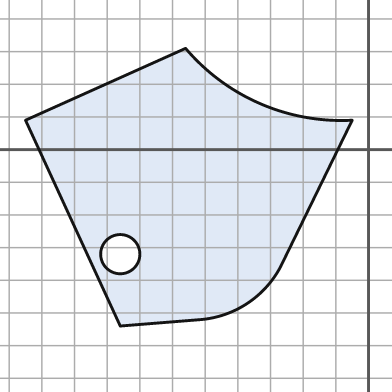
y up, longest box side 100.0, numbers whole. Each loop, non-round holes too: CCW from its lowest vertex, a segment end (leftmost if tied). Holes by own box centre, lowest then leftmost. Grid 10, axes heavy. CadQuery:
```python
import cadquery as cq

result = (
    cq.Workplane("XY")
    .moveTo(-76.0, -54.0)
    .lineTo(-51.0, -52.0)
    .threePointArc((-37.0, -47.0), (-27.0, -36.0))
    .lineTo(-5.0, 9.0)
    .threePointArc((-33.0, 14.0), (-56.0, 31.0))
    .lineTo(-105.0, 9.0)
    .close()
    .moveTo(-76.0, -32.0)
    .circle(6.0)
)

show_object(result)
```